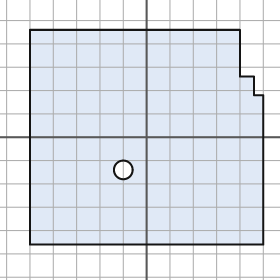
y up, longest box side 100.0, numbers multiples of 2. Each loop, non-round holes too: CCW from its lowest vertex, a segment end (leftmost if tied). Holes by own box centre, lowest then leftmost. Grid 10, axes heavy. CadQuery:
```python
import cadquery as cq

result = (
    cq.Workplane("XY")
    .moveTo(-50.0, -46.0)
    .lineTo(50.0, -46.0)
    .lineTo(50.0, 18.0)
    .lineTo(46.0, 18.0)
    .lineTo(46.0, 26.0)
    .lineTo(40.0, 26.0)
    .lineTo(40.0, 46.0)
    .lineTo(-50.0, 46.0)
    .close()
    .moveTo(-10.0, -14.0)
    .circle(4.0)
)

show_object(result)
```